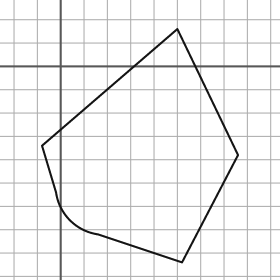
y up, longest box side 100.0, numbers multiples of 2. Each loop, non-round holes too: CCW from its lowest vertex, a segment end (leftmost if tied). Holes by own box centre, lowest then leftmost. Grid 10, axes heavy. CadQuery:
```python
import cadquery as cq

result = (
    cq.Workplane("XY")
    .moveTo(52.0, -84.0)
    .lineTo(76.0, -38.0)
    .lineTo(50.0, 16.0)
    .lineTo(-8.0, -34.0)
    .lineTo(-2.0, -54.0)
    .threePointArc((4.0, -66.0), (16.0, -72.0))
    .close()
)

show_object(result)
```